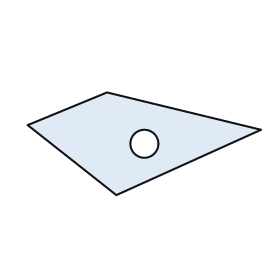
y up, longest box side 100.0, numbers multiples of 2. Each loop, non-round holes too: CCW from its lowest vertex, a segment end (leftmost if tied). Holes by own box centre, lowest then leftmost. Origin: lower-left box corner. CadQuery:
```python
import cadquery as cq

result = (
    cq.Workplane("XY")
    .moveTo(38.0, 0.0)
    .lineTo(100.0, 28.0)
    .lineTo(34.0, 44.0)
    .lineTo(0.0, 30.0)
    .close()
    .moveTo(50.0, 22.0)
    .circle(6.0)
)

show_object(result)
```